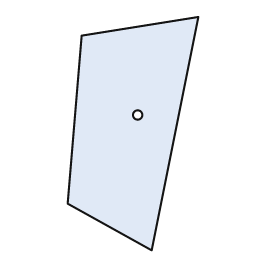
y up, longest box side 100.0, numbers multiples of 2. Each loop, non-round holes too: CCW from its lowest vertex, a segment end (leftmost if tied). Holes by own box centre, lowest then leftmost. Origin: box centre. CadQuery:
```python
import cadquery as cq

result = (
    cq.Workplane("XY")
    .moveTo(8.0, -50.0)
    .lineTo(28.0, 50.0)
    .lineTo(-22.0, 42.0)
    .lineTo(-28.0, -30.0)
    .close()
    .moveTo(2.0, 8.0)
    .circle(2.0)
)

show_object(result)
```